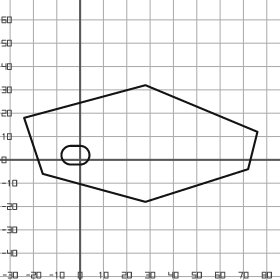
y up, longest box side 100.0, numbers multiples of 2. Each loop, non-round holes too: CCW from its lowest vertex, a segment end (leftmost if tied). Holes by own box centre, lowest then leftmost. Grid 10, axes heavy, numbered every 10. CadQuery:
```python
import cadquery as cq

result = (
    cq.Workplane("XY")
    .moveTo(28.0, -18.0)
    .lineTo(72.0, -4.0)
    .lineTo(76.0, 12.0)
    .lineTo(28.0, 32.0)
    .lineTo(-24.0, 18.0)
    .lineTo(-16.0, -6.0)
    .close()
    .moveTo(-4.0, -2.0)
    .lineTo(0.0, -2.0)
    .threePointArc((4.0, 2.0), (0.0, 6.0))
    .lineTo(-4.0, 6.0)
    .threePointArc((-8.0, 2.0), (-4.0, -2.0))
    .close()
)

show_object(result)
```